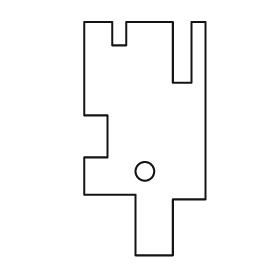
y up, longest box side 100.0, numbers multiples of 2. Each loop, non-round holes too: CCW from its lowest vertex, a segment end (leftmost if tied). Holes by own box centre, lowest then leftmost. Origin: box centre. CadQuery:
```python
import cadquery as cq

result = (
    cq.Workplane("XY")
    .moveTo(-4.0, -50.0)
    .lineTo(12.0, -50.0)
    .lineTo(12.0, -26.0)
    .lineTo(26.0, -26.0)
    .lineTo(26.0, 50.0)
    .lineTo(20.0, 50.0)
    .lineTo(20.0, 24.0)
    .lineTo(12.0, 24.0)
    .lineTo(12.0, 50.0)
    .lineTo(-8.0, 50.0)
    .lineTo(-8.0, 40.0)
    .lineTo(-14.0, 40.0)
    .lineTo(-14.0, 50.0)
    .lineTo(-26.0, 50.0)
    .lineTo(-26.0, 10.0)
    .lineTo(-16.0, 10.0)
    .lineTo(-16.0, -8.0)
    .lineTo(-26.0, -8.0)
    .lineTo(-26.0, -24.0)
    .lineTo(-4.0, -24.0)
    .close()
    .moveTo(0.0, -14.0)
    .circle(4.0)
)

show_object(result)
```